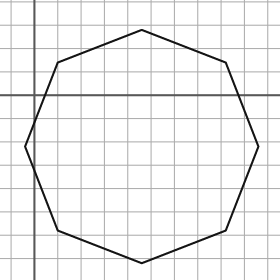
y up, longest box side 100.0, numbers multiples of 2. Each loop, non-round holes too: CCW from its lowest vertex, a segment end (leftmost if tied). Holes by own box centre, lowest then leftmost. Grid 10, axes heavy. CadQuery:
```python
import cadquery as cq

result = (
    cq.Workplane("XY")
    .moveTo(46.0, -72.0)
    .lineTo(82.0, -58.0)
    .lineTo(96.0, -22.0)
    .lineTo(82.0, 14.0)
    .lineTo(46.0, 28.0)
    .lineTo(10.0, 14.0)
    .lineTo(-4.0, -22.0)
    .lineTo(10.0, -58.0)
    .close()
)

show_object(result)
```